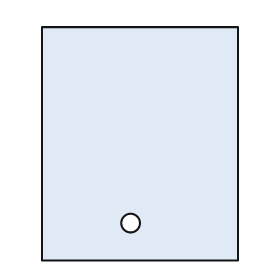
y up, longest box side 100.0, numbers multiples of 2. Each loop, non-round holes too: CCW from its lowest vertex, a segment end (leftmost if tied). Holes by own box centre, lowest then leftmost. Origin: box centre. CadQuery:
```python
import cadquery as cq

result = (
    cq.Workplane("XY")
    .moveTo(-42.0, -50.0)
    .lineTo(42.0, -50.0)
    .lineTo(42.0, 50.0)
    .lineTo(-42.0, 50.0)
    .close()
    .moveTo(-4.0, -34.0)
    .circle(4.0)
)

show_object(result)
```